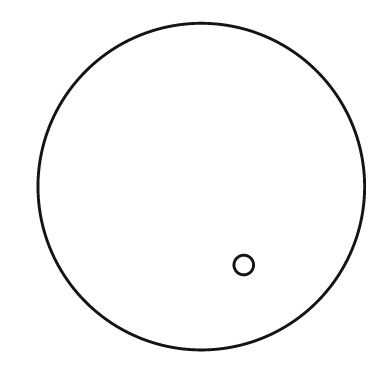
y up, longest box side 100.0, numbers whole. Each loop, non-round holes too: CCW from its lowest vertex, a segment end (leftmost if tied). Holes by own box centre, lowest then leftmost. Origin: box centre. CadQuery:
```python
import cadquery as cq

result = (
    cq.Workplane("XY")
    .moveTo(0.0, 0.0)
    .circle(50.0)
    .moveTo(13.0, -24.0)
    .circle(3.0)
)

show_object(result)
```